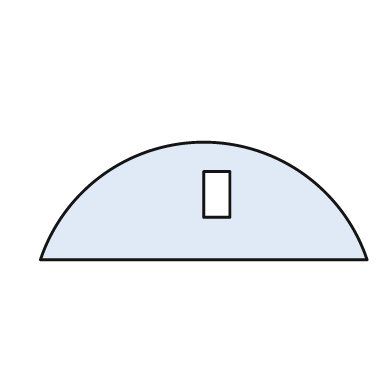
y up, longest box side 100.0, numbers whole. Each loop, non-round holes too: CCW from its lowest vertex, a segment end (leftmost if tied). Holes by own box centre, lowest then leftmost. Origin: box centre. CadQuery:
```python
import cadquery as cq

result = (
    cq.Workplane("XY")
    .moveTo(-50.0, -18.0)
    .lineTo(50.0, -18.0)
    .threePointArc((0.0, 18.0), (-50.0, -18.0))
    .close()
    .moveTo(0.0, -5.0)
    .lineTo(8.0, -5.0)
    .lineTo(8.0, 9.0)
    .lineTo(0.0, 9.0)
    .close()
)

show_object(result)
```